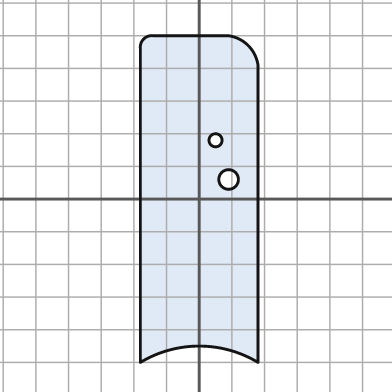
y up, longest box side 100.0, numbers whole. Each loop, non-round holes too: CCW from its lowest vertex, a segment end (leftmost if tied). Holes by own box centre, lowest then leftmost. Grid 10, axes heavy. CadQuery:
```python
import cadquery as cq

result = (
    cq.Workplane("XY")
    .moveTo(-18.0, -50.0)
    .threePointArc((0.0, -45.0), (18.0, -50.0))
    .lineTo(18.0, 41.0)
    .threePointArc((15.0, 47.0), (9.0, 50.0))
    .lineTo(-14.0, 50.0)
    .threePointArc((-17.0, 49.0), (-18.0, 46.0))
    .close()
    .moveTo(9.0, 6.0)
    .circle(3.0)
    .moveTo(5.0, 18.0)
    .circle(2.0)
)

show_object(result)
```